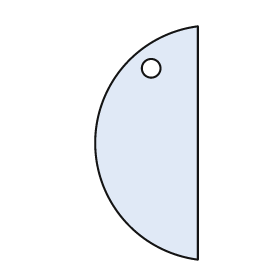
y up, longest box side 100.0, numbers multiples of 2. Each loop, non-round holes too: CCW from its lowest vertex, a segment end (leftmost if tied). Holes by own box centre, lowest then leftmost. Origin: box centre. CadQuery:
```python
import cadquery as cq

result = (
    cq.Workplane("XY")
    .moveTo(22.0, -50.0)
    .lineTo(22.0, 50.0)
    .threePointArc((-22.0, 0.0), (22.0, -50.0))
    .close()
    .moveTo(2.0, 32.0)
    .circle(4.0)
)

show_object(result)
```